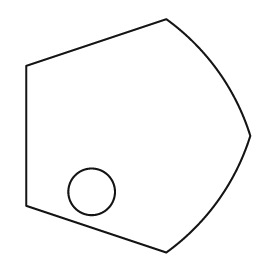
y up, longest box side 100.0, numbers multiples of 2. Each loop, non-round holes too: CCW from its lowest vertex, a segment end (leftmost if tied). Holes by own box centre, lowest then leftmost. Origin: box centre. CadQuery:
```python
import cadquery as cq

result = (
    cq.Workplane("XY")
    .moveTo(12.0, -50.0)
    .threePointArc((34.0, -28.0), (48.0, 0.0))
    .threePointArc((34.0, 28.0), (12.0, 50.0))
    .lineTo(-48.0, 30.0)
    .lineTo(-48.0, -30.0)
    .close()
    .moveTo(-20.0, -24.0)
    .circle(10.0)
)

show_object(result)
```